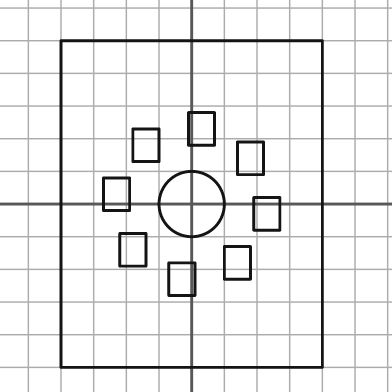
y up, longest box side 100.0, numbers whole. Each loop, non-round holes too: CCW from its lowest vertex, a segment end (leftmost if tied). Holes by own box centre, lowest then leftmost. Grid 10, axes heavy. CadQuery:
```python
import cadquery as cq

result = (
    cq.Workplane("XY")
    .moveTo(-40.0, -50.0)
    .lineTo(40.0, -50.0)
    .lineTo(40.0, 50.0)
    .lineTo(-40.0, 50.0)
    .close()
    .moveTo(-7.0, -28.0)
    .lineTo(1.0, -28.0)
    .lineTo(1.0, -18.0)
    .lineTo(-7.0, -18.0)
    .close()
    .moveTo(10.0, -23.0)
    .lineTo(18.0, -23.0)
    .lineTo(18.0, -13.0)
    .lineTo(10.0, -13.0)
    .close()
    .moveTo(-22.0, -19.0)
    .lineTo(-14.0, -19.0)
    .lineTo(-14.0, -9.0)
    .lineTo(-22.0, -9.0)
    .close()
    .moveTo(19.0, -8.0)
    .lineTo(27.0, -8.0)
    .lineTo(27.0, 2.0)
    .lineTo(19.0, 2.0)
    .close()
    .moveTo(0.0, 0.0)
    .circle(10.0)
    .moveTo(-27.0, -2.0)
    .lineTo(-19.0, -2.0)
    .lineTo(-19.0, 8.0)
    .lineTo(-27.0, 8.0)
    .close()
    .moveTo(14.0, 9.0)
    .lineTo(22.0, 9.0)
    .lineTo(22.0, 19.0)
    .lineTo(14.0, 19.0)
    .close()
    .moveTo(-18.0, 13.0)
    .lineTo(-10.0, 13.0)
    .lineTo(-10.0, 23.0)
    .lineTo(-18.0, 23.0)
    .close()
    .moveTo(-1.0, 18.0)
    .lineTo(7.0, 18.0)
    .lineTo(7.0, 28.0)
    .lineTo(-1.0, 28.0)
    .close()
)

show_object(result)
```